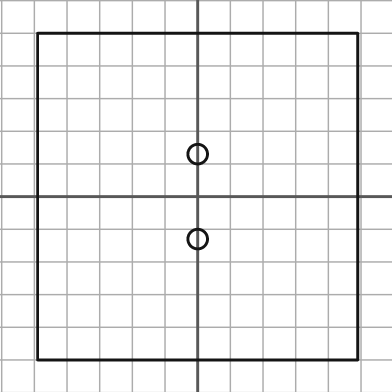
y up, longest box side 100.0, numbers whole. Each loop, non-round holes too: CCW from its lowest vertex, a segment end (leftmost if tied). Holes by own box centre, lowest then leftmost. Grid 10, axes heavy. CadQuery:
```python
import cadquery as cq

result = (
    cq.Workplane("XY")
    .moveTo(-49.0, -50.0)
    .lineTo(49.0, -50.0)
    .lineTo(49.0, 50.0)
    .lineTo(-49.0, 50.0)
    .close()
    .moveTo(0.0, -13.0)
    .circle(3.0)
    .moveTo(0.0, 13.0)
    .circle(3.0)
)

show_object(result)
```